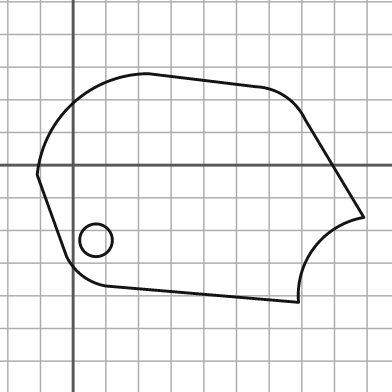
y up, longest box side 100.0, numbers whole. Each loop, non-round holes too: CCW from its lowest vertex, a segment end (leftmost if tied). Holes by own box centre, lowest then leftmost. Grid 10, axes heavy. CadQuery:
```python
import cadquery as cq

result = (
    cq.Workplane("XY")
    .moveTo(69.0, -42.0)
    .threePointArc((74.0, -25.0), (89.0, -16.0))
    .lineTo(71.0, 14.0)
    .threePointArc((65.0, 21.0), (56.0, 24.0))
    .lineTo(23.0, 28.0)
    .threePointArc((0.0, 19.0), (-11.0, -3.0))
    .lineTo(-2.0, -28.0)
    .threePointArc((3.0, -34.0), (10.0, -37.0))
    .close()
    .moveTo(7.0, -23.0)
    .circle(5.0)
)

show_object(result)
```